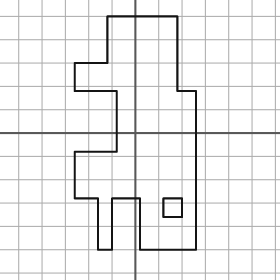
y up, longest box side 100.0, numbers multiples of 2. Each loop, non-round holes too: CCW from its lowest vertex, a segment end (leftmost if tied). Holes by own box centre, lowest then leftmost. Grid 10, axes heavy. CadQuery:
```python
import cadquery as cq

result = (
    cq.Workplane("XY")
    .moveTo(-16.0, -50.0)
    .lineTo(-10.0, -50.0)
    .lineTo(-10.0, -28.0)
    .lineTo(2.0, -28.0)
    .lineTo(2.0, -50.0)
    .lineTo(26.0, -50.0)
    .lineTo(26.0, 18.0)
    .lineTo(18.0, 18.0)
    .lineTo(18.0, 50.0)
    .lineTo(-12.0, 50.0)
    .lineTo(-12.0, 30.0)
    .lineTo(-26.0, 30.0)
    .lineTo(-26.0, 18.0)
    .lineTo(-8.0, 18.0)
    .lineTo(-8.0, -8.0)
    .lineTo(-26.0, -8.0)
    .lineTo(-26.0, -28.0)
    .lineTo(-16.0, -28.0)
    .close()
    .moveTo(12.0, -36.0)
    .lineTo(20.0, -36.0)
    .lineTo(20.0, -28.0)
    .lineTo(12.0, -28.0)
    .close()
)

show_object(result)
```